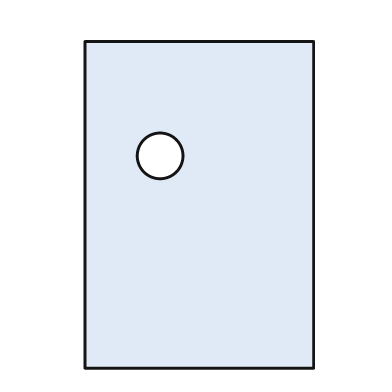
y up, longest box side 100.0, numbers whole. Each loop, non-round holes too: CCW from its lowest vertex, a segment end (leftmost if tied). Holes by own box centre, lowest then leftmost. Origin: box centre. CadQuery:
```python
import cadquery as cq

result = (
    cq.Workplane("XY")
    .moveTo(-35.0, -50.0)
    .lineTo(35.0, -50.0)
    .lineTo(35.0, 50.0)
    .lineTo(-35.0, 50.0)
    .close()
    .moveTo(-12.0, 15.0)
    .circle(7.0)
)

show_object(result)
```